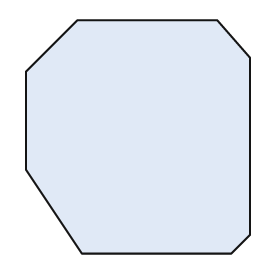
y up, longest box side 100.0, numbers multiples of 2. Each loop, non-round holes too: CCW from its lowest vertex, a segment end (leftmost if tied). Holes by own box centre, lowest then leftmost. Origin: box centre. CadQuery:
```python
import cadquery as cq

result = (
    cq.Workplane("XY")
    .moveTo(-24.0, -50.0)
    .lineTo(40.0, -50.0)
    .lineTo(48.0, -42.0)
    .lineTo(48.0, 34.0)
    .lineTo(34.0, 50.0)
    .lineTo(-26.0, 50.0)
    .lineTo(-48.0, 28.0)
    .lineTo(-48.0, -14.0)
    .close()
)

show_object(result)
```